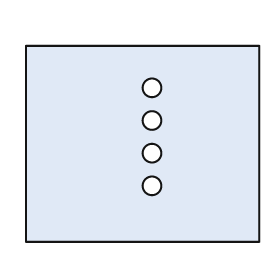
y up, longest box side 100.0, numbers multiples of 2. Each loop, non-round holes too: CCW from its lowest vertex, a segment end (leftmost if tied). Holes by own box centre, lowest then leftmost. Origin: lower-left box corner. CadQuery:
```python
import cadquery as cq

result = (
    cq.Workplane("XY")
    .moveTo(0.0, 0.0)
    .lineTo(100.0, 0.0)
    .lineTo(100.0, 84.0)
    .lineTo(0.0, 84.0)
    .close()
    .moveTo(54.0, 24.0)
    .circle(4.0)
    .moveTo(54.0, 38.0)
    .circle(4.0)
    .moveTo(54.0, 52.0)
    .circle(4.0)
    .moveTo(54.0, 66.0)
    .circle(4.0)
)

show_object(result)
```